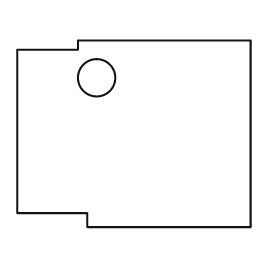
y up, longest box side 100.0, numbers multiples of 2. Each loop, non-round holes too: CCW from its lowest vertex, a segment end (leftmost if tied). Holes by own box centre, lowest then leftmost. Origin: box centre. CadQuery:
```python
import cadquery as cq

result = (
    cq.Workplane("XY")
    .moveTo(-20.0, -40.0)
    .lineTo(50.0, -40.0)
    .lineTo(50.0, 40.0)
    .lineTo(-24.0, 40.0)
    .lineTo(-24.0, 36.0)
    .lineTo(-50.0, 36.0)
    .lineTo(-50.0, -34.0)
    .lineTo(-20.0, -34.0)
    .close()
    .moveTo(-16.0, 24.0)
    .circle(8.0)
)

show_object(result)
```